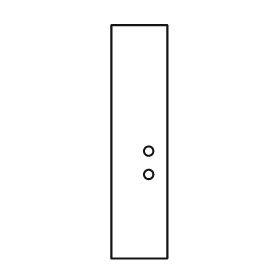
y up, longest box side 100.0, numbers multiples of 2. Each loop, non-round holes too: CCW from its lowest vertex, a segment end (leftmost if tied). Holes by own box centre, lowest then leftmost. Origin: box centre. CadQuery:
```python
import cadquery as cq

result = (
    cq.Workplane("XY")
    .moveTo(-12.0, -50.0)
    .lineTo(12.0, -50.0)
    .lineTo(12.0, 50.0)
    .lineTo(-12.0, 50.0)
    .close()
    .moveTo(4.0, -14.0)
    .circle(2.0)
    .moveTo(4.0, -4.0)
    .circle(2.0)
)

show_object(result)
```